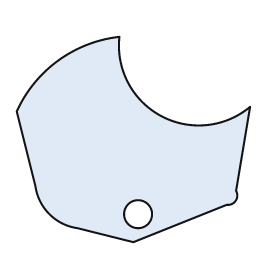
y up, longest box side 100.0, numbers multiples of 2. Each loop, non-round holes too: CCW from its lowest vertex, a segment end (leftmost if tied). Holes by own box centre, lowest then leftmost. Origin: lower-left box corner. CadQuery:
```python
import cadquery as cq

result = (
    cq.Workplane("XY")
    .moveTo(50.0, 0.0)
    .lineTo(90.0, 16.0)
    .threePointArc((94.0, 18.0), (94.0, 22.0))
    .lineTo(100.0, 58.0)
    .threePointArc((62.0, 54.0), (44.0, 88.0))
    .threePointArc((18.0, 78.0), (0.0, 56.0))
    .lineTo(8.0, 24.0)
    .threePointArc((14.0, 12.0), (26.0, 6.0))
    .close()
    .moveTo(52.0, 12.0)
    .circle(6.0)
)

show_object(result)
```